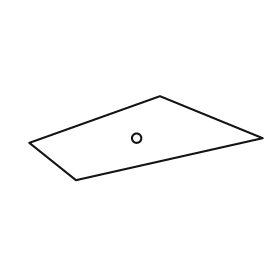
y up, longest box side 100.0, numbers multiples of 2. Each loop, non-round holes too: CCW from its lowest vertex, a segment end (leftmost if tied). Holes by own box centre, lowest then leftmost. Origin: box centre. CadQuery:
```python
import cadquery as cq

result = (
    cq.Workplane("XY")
    .moveTo(-30.0, -18.0)
    .lineTo(50.0, 0.0)
    .lineTo(6.0, 18.0)
    .lineTo(-50.0, -2.0)
    .close()
    .moveTo(-4.0, 0.0)
    .circle(2.0)
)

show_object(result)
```